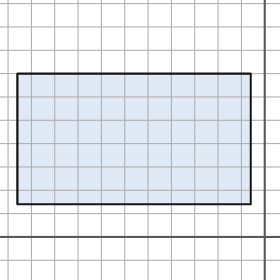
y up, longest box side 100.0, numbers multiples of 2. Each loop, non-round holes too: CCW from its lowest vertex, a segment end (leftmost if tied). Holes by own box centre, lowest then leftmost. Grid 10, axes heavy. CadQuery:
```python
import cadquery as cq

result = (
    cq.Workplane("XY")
    .moveTo(-106.0, 14.0)
    .lineTo(-6.0, 14.0)
    .lineTo(-6.0, 70.0)
    .lineTo(-106.0, 70.0)
    .close()
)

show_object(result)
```